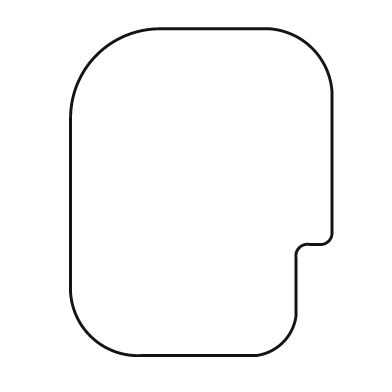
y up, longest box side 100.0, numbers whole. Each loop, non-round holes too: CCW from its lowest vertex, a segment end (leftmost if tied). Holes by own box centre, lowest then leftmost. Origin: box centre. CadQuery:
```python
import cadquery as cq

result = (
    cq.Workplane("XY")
    .moveTo(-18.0, -50.0)
    .lineTo(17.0, -50.0)
    .threePointArc((25.0, -46.0), (29.0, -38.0))
    .lineTo(29.0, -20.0)
    .threePointArc((30.0, -17.0), (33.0, -16.0))
    .lineTo(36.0, -16.0)
    .threePointArc((39.0, -15.0), (40.0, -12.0))
    .lineTo(40.0, 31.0)
    .threePointArc((34.0, 44.0), (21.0, 50.0))
    .lineTo(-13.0, 50.0)
    .threePointArc((-32.0, 42.0), (-40.0, 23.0))
    .lineTo(-40.0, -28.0)
    .threePointArc((-34.0, -44.0), (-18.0, -50.0))
    .close()
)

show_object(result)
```